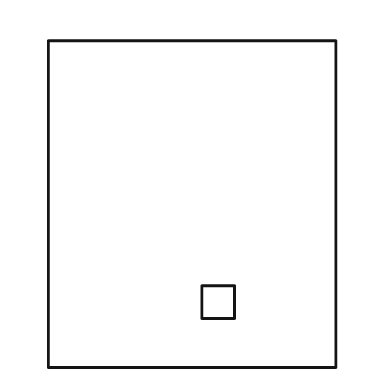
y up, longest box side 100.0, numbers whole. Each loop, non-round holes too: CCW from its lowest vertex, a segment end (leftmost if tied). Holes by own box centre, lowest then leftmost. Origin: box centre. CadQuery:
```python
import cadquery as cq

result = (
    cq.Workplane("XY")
    .moveTo(-44.0, -50.0)
    .lineTo(44.0, -50.0)
    .lineTo(44.0, 50.0)
    .lineTo(-44.0, 50.0)
    .close()
    .moveTo(3.0, -35.0)
    .lineTo(13.0, -35.0)
    .lineTo(13.0, -25.0)
    .lineTo(3.0, -25.0)
    .close()
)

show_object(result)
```